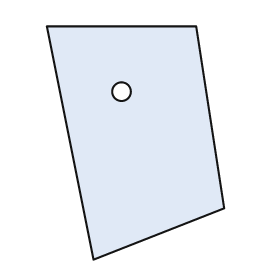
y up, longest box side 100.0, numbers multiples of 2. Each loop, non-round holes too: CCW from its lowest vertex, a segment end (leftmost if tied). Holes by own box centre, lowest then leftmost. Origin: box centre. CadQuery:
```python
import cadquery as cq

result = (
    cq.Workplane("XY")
    .moveTo(-18.0, -50.0)
    .lineTo(38.0, -28.0)
    .lineTo(26.0, 50.0)
    .lineTo(-38.0, 50.0)
    .close()
    .moveTo(-6.0, 22.0)
    .circle(4.0)
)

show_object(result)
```